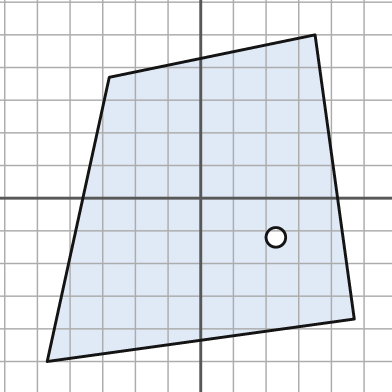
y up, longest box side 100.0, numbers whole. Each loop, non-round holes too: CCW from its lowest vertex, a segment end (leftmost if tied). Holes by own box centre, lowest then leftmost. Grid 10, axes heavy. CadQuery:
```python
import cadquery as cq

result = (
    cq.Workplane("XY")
    .moveTo(-47.0, -50.0)
    .lineTo(47.0, -37.0)
    .lineTo(35.0, 50.0)
    .lineTo(-28.0, 37.0)
    .close()
    .moveTo(23.0, -12.0)
    .circle(3.0)
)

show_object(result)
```